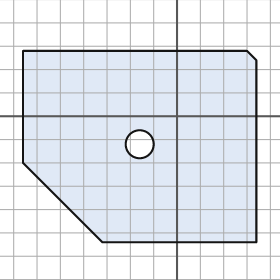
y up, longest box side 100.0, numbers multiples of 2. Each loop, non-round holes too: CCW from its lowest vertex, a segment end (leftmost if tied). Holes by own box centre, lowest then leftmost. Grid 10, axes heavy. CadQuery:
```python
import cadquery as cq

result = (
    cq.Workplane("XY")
    .moveTo(-32.0, -54.0)
    .lineTo(34.0, -54.0)
    .lineTo(34.0, 24.0)
    .lineTo(30.0, 28.0)
    .lineTo(-66.0, 28.0)
    .lineTo(-66.0, -20.0)
    .close()
    .moveTo(-16.0, -12.0)
    .circle(6.0)
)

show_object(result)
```